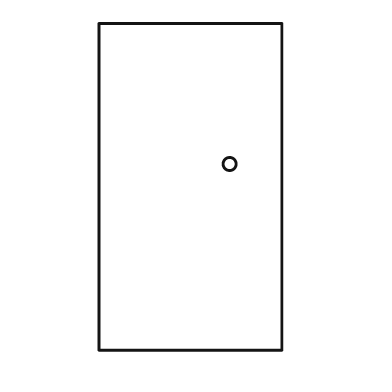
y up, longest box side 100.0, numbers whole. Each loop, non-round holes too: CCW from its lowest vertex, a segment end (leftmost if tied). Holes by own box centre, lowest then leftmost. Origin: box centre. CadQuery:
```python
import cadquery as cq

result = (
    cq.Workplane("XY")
    .moveTo(-28.0, -50.0)
    .lineTo(28.0, -50.0)
    .lineTo(28.0, 50.0)
    .lineTo(-28.0, 50.0)
    .close()
    .moveTo(12.0, 7.0)
    .circle(2.0)
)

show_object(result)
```